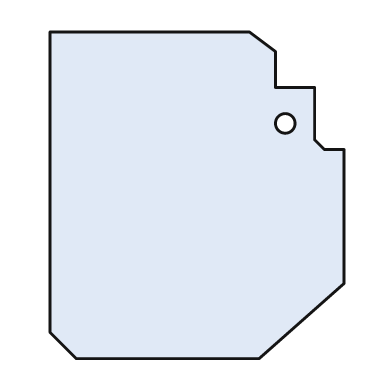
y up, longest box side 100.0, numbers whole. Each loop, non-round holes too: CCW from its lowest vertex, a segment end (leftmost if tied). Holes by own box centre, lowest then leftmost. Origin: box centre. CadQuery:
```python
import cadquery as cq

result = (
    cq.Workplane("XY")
    .moveTo(-37.0, -50.0)
    .lineTo(19.0, -50.0)
    .lineTo(45.0, -27.0)
    .lineTo(45.0, 14.0)
    .lineTo(39.0, 14.0)
    .lineTo(36.0, 17.0)
    .lineTo(36.0, 33.0)
    .lineTo(24.0, 33.0)
    .lineTo(24.0, 44.0)
    .lineTo(16.0, 50.0)
    .lineTo(-45.0, 50.0)
    .lineTo(-45.0, -42.0)
    .close()
    .moveTo(27.0, 22.0)
    .circle(3.0)
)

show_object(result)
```